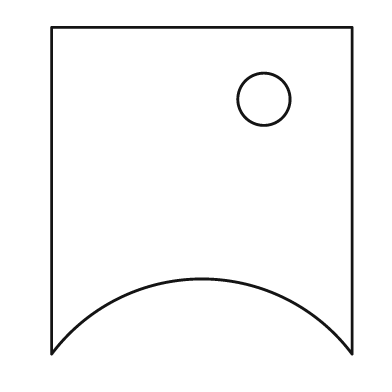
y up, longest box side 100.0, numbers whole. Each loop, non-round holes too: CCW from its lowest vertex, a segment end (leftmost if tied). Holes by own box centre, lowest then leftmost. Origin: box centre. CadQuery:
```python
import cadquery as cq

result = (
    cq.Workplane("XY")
    .moveTo(-46.0, -50.0)
    .threePointArc((0.0, -27.0), (46.0, -50.0))
    .lineTo(46.0, 50.0)
    .lineTo(-46.0, 50.0)
    .close()
    .moveTo(19.0, 28.0)
    .circle(8.0)
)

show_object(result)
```